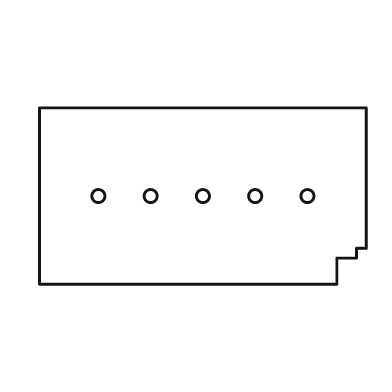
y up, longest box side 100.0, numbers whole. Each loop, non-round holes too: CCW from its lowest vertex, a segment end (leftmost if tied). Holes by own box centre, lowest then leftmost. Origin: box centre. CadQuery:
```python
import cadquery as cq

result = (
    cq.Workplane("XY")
    .moveTo(-50.0, -27.0)
    .lineTo(41.0, -27.0)
    .lineTo(41.0, -19.0)
    .lineTo(47.0, -19.0)
    .lineTo(47.0, -16.0)
    .lineTo(50.0, -16.0)
    .lineTo(50.0, 27.0)
    .lineTo(-50.0, 27.0)
    .close()
    .moveTo(-32.0, 0.0)
    .circle(2.0)
    .moveTo(-16.0, 0.0)
    .circle(2.0)
    .moveTo(0.0, 0.0)
    .circle(2.0)
    .moveTo(16.0, 0.0)
    .circle(2.0)
    .moveTo(32.0, 0.0)
    .circle(2.0)
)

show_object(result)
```